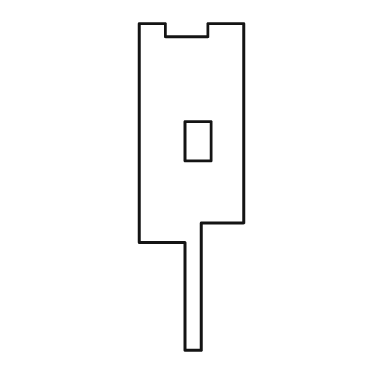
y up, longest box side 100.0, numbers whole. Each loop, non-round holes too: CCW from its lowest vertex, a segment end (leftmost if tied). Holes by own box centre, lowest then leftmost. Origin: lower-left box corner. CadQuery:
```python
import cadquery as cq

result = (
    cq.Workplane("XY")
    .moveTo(14.0, 0.0)
    .lineTo(19.0, 0.0)
    .lineTo(19.0, 39.0)
    .lineTo(32.0, 39.0)
    .lineTo(32.0, 100.0)
    .lineTo(21.0, 100.0)
    .lineTo(21.0, 96.0)
    .lineTo(8.0, 96.0)
    .lineTo(8.0, 100.0)
    .lineTo(0.0, 100.0)
    .lineTo(0.0, 33.0)
    .lineTo(14.0, 33.0)
    .close()
    .moveTo(14.0, 58.0)
    .lineTo(22.0, 58.0)
    .lineTo(22.0, 70.0)
    .lineTo(14.0, 70.0)
    .close()
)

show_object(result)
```